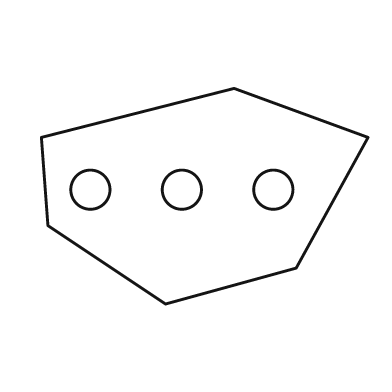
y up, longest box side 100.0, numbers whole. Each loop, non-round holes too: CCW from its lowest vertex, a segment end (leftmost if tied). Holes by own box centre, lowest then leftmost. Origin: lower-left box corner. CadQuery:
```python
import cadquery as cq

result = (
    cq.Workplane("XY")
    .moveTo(38.0, 0.0)
    .lineTo(78.0, 11.0)
    .lineTo(100.0, 51.0)
    .lineTo(59.0, 66.0)
    .lineTo(0.0, 51.0)
    .lineTo(2.0, 24.0)
    .close()
    .moveTo(15.0, 35.0)
    .circle(6.0)
    .moveTo(43.0, 35.0)
    .circle(6.0)
    .moveTo(71.0, 35.0)
    .circle(6.0)
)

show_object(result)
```